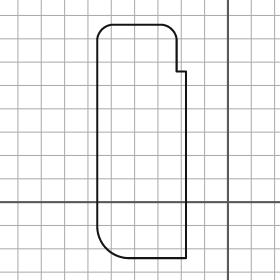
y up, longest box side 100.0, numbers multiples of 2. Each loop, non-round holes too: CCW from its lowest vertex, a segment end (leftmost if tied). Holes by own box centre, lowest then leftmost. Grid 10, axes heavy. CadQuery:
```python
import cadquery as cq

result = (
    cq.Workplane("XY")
    .moveTo(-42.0, -24.0)
    .lineTo(-18.0, -24.0)
    .lineTo(-18.0, 56.0)
    .lineTo(-22.0, 56.0)
    .lineTo(-22.0, 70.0)
    .threePointArc((-24.0, 74.0), (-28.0, 76.0))
    .lineTo(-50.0, 76.0)
    .threePointArc((-54.0, 74.0), (-56.0, 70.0))
    .lineTo(-56.0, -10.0)
    .threePointArc((-52.0, -20.0), (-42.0, -24.0))
    .close()
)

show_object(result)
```